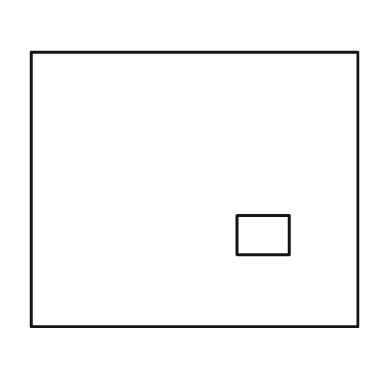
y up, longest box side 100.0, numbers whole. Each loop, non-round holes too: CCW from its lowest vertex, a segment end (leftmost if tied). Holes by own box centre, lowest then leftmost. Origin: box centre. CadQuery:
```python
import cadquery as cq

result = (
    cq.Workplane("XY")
    .moveTo(-50.0, -42.0)
    .lineTo(50.0, -42.0)
    .lineTo(50.0, 42.0)
    .lineTo(-50.0, 42.0)
    .close()
    .moveTo(13.0, -20.0)
    .lineTo(29.0, -20.0)
    .lineTo(29.0, -8.0)
    .lineTo(13.0, -8.0)
    .close()
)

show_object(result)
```